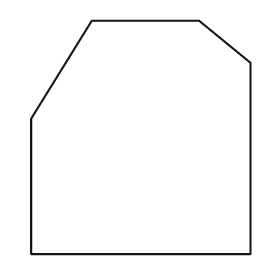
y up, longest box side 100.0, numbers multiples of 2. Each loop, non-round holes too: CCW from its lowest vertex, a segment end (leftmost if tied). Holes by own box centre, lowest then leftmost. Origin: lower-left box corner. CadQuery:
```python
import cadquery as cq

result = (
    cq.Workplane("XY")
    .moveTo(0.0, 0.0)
    .lineTo(94.0, 0.0)
    .lineTo(94.0, 82.0)
    .lineTo(72.0, 100.0)
    .lineTo(26.0, 100.0)
    .lineTo(0.0, 58.0)
    .close()
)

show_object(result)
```